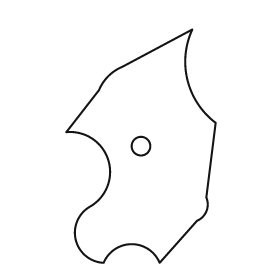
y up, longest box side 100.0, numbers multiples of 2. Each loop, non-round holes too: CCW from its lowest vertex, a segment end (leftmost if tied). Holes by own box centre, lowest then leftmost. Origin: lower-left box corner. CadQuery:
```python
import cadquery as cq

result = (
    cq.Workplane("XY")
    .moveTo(16.0, 0.0)
    .threePointArc((28.0, 8.0), (40.0, 0.0))
    .lineTo(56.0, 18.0)
    .threePointArc((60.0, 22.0), (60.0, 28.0))
    .lineTo(64.0, 60.0)
    .threePointArc((52.0, 78.0), (54.0, 100.0))
    .lineTo(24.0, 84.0)
    .threePointArc((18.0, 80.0), (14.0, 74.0))
    .lineTo(0.0, 56.0)
    .threePointArc((18.0, 44.0), (10.0, 24.0))
    .threePointArc((4.0, 10.0), (16.0, 0.0))
    .close()
    .moveTo(32.0, 50.0)
    .circle(4.0)
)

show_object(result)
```